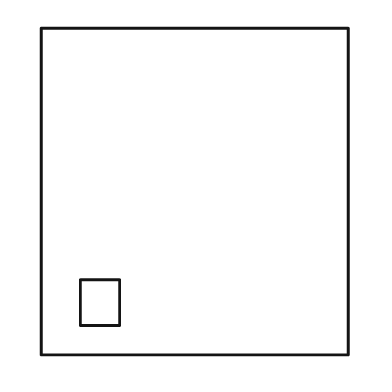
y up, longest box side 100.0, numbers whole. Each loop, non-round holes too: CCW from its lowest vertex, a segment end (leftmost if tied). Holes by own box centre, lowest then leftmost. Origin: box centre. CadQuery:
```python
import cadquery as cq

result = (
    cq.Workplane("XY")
    .moveTo(-47.0, -50.0)
    .lineTo(47.0, -50.0)
    .lineTo(47.0, 50.0)
    .lineTo(-47.0, 50.0)
    .close()
    .moveTo(-35.0, -41.0)
    .lineTo(-23.0, -41.0)
    .lineTo(-23.0, -27.0)
    .lineTo(-35.0, -27.0)
    .close()
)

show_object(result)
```